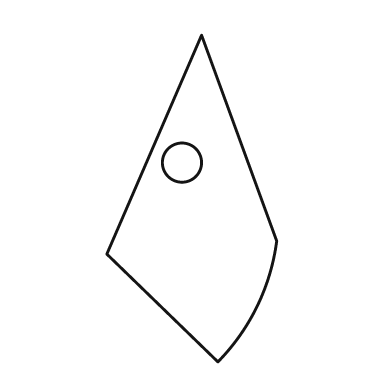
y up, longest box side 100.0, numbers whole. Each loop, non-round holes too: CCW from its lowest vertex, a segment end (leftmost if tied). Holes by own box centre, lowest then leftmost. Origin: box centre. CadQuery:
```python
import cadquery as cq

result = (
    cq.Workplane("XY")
    .moveTo(8.0, -50.0)
    .threePointArc((20.0, -33.0), (26.0, -13.0))
    .lineTo(3.0, 50.0)
    .lineTo(-26.0, -17.0)
    .close()
    .moveTo(-3.0, 11.0)
    .circle(6.0)
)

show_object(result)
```